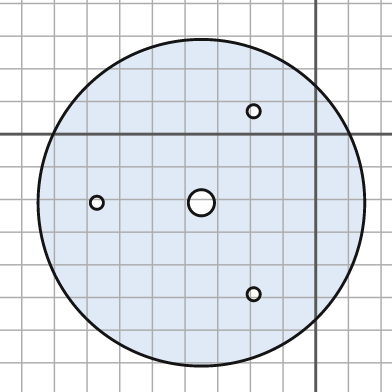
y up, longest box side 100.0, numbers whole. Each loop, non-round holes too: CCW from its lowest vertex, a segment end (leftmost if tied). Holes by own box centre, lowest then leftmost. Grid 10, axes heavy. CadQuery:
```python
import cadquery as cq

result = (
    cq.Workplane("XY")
    .moveTo(-35.0, -21.0)
    .circle(50.0)
    .moveTo(-19.0, -49.0)
    .circle(2.0)
    .moveTo(-67.0, -21.0)
    .circle(2.0)
    .moveTo(-35.0, -21.0)
    .circle(4.0)
    .moveTo(-19.0, 7.0)
    .circle(2.0)
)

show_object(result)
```